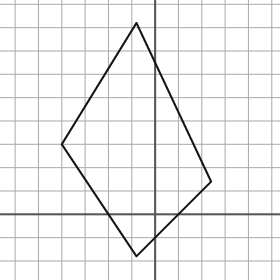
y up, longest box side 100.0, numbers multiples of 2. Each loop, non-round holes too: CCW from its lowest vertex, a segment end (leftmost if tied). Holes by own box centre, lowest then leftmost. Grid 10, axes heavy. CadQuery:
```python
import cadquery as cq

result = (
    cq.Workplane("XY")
    .moveTo(-8.0, -18.0)
    .lineTo(24.0, 14.0)
    .lineTo(-8.0, 82.0)
    .lineTo(-40.0, 30.0)
    .close()
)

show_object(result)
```